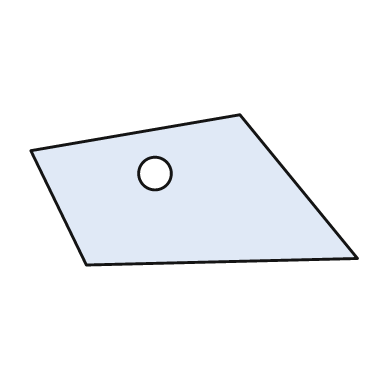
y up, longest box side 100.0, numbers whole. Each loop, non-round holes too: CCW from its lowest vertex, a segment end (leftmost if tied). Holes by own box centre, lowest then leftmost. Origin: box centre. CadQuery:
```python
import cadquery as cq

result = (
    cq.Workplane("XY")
    .moveTo(-33.0, -23.0)
    .lineTo(50.0, -21.0)
    .lineTo(14.0, 23.0)
    .lineTo(-50.0, 12.0)
    .close()
    .moveTo(-12.0, 5.0)
    .circle(5.0)
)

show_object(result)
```